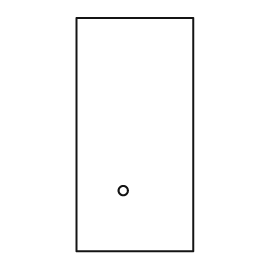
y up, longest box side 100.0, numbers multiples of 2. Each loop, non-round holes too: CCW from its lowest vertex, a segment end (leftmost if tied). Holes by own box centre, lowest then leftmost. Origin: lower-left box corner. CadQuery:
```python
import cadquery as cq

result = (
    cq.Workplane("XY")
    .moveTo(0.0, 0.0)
    .lineTo(50.0, 0.0)
    .lineTo(50.0, 100.0)
    .lineTo(0.0, 100.0)
    .close()
    .moveTo(20.0, 26.0)
    .circle(2.0)
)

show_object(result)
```